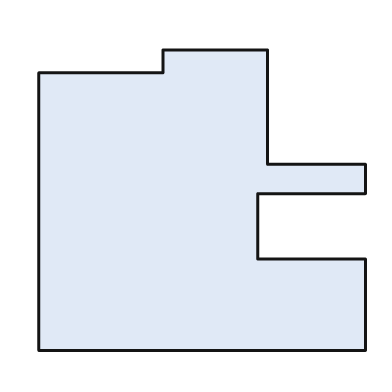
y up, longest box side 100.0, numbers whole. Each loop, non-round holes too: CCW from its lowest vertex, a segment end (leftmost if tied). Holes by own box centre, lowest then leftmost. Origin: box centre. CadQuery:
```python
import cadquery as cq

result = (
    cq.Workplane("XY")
    .moveTo(-50.0, -46.0)
    .lineTo(50.0, -46.0)
    .lineTo(50.0, -18.0)
    .lineTo(17.0, -18.0)
    .lineTo(17.0, 2.0)
    .lineTo(50.0, 2.0)
    .lineTo(50.0, 11.0)
    .lineTo(20.0, 11.0)
    .lineTo(20.0, 46.0)
    .lineTo(-12.0, 46.0)
    .lineTo(-12.0, 39.0)
    .lineTo(-50.0, 39.0)
    .close()
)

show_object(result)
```